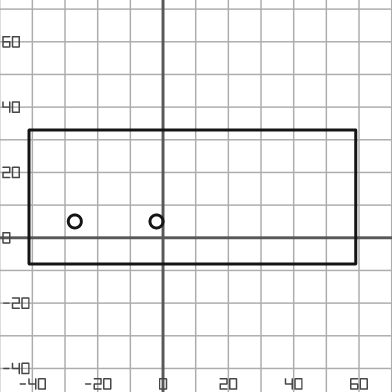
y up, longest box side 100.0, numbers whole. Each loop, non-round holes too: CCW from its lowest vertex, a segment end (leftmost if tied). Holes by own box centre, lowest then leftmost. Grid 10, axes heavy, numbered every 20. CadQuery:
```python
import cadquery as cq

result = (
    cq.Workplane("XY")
    .moveTo(-41.0, -8.0)
    .lineTo(59.0, -8.0)
    .lineTo(59.0, 33.0)
    .lineTo(-41.0, 33.0)
    .close()
    .moveTo(-27.0, 5.0)
    .circle(2.0)
    .moveTo(-2.0, 5.0)
    .circle(2.0)
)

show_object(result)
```